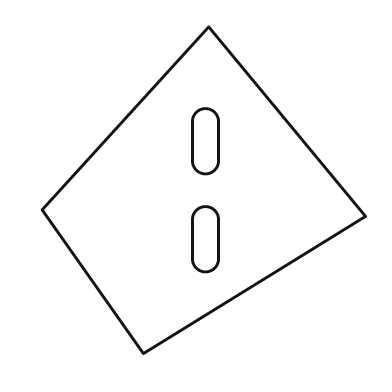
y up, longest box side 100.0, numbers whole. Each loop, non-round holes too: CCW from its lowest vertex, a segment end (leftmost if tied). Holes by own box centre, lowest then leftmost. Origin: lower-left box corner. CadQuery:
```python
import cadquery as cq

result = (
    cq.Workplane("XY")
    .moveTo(31.0, 0.0)
    .lineTo(99.0, 42.0)
    .lineTo(51.0, 100.0)
    .lineTo(0.0, 44.0)
    .close()
    .moveTo(46.0, 29.0)
    .threePointArc((50.0, 25.0), (54.0, 29.0))
    .lineTo(54.0, 41.0)
    .threePointArc((50.0, 45.0), (46.0, 41.0))
    .close()
    .moveTo(46.0, 59.0)
    .threePointArc((50.0, 55.0), (54.0, 59.0))
    .lineTo(54.0, 71.0)
    .threePointArc((50.0, 75.0), (46.0, 71.0))
    .close()
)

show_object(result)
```